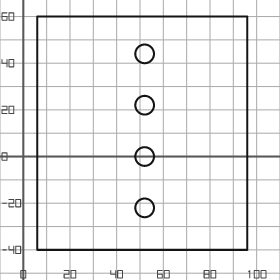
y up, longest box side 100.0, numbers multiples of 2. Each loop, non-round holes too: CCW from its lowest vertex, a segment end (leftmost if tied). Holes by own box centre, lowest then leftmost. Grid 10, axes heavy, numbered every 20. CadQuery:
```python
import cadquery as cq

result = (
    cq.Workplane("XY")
    .moveTo(6.0, -40.0)
    .lineTo(96.0, -40.0)
    .lineTo(96.0, 60.0)
    .lineTo(6.0, 60.0)
    .close()
    .moveTo(52.0, -22.0)
    .circle(4.0)
    .moveTo(52.0, 0.0)
    .circle(4.0)
    .moveTo(52.0, 22.0)
    .circle(4.0)
    .moveTo(52.0, 44.0)
    .circle(4.0)
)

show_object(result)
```